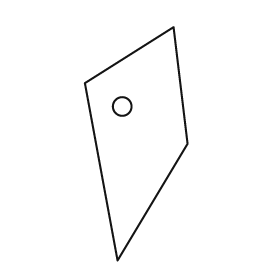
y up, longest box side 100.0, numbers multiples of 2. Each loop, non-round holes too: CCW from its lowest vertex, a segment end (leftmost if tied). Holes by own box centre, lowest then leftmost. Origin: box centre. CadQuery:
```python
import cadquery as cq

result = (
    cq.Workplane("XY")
    .moveTo(-8.0, -50.0)
    .lineTo(22.0, 0.0)
    .lineTo(16.0, 50.0)
    .lineTo(-22.0, 26.0)
    .close()
    .moveTo(-6.0, 16.0)
    .circle(4.0)
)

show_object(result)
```